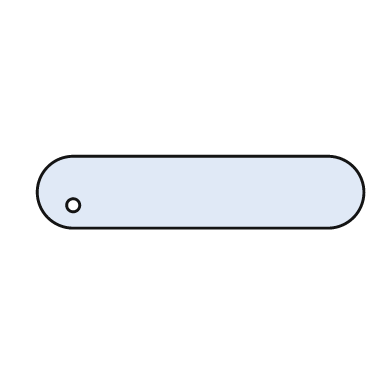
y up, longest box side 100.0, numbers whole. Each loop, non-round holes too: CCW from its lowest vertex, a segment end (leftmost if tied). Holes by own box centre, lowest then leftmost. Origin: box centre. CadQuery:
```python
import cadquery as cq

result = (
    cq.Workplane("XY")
    .moveTo(-39.0, -11.0)
    .lineTo(39.0, -11.0)
    .threePointArc((50.0, 0.0), (39.0, 11.0))
    .lineTo(-39.0, 11.0)
    .threePointArc((-50.0, 0.0), (-39.0, -11.0))
    .close()
    .moveTo(-39.0, -4.0)
    .circle(2.0)
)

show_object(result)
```